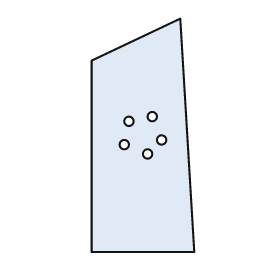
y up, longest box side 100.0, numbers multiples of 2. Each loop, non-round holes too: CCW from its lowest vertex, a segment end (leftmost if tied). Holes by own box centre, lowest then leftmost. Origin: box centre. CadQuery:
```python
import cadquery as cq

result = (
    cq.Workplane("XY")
    .moveTo(-22.0, -50.0)
    .lineTo(22.0, -50.0)
    .lineTo(16.0, 50.0)
    .lineTo(-22.0, 32.0)
    .close()
    .moveTo(2.0, -8.0)
    .circle(2.0)
    .moveTo(-8.0, -4.0)
    .circle(2.0)
    .moveTo(8.0, -2.0)
    .circle(2.0)
    .moveTo(-6.0, 6.0)
    .circle(2.0)
    .moveTo(4.0, 8.0)
    .circle(2.0)
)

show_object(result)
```